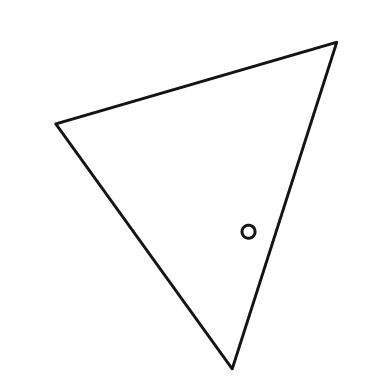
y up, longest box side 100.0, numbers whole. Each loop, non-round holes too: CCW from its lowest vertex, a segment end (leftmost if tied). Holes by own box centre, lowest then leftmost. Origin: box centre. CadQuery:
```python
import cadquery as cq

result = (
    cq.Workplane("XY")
    .moveTo(11.0, -50.0)
    .lineTo(43.0, 50.0)
    .lineTo(-43.0, 25.0)
    .close()
    .moveTo(16.0, -8.0)
    .circle(2.0)
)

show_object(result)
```